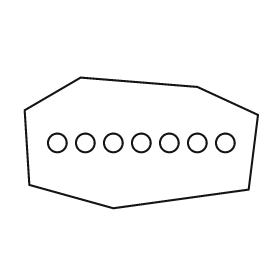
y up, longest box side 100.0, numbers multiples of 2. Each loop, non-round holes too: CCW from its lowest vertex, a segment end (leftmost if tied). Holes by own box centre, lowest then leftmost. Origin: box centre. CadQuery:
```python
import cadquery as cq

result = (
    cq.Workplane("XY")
    .moveTo(-12.0, -28.0)
    .lineTo(46.0, -20.0)
    .lineTo(50.0, 12.0)
    .lineTo(24.0, 24.0)
    .lineTo(-26.0, 28.0)
    .lineTo(-50.0, 14.0)
    .lineTo(-48.0, -18.0)
    .close()
    .moveTo(-36.0, 0.0)
    .circle(4.0)
    .moveTo(-24.0, 0.0)
    .circle(4.0)
    .moveTo(-12.0, 0.0)
    .circle(4.0)
    .moveTo(0.0, 0.0)
    .circle(4.0)
    .moveTo(12.0, 0.0)
    .circle(4.0)
    .moveTo(24.0, 0.0)
    .circle(4.0)
    .moveTo(36.0, 0.0)
    .circle(4.0)
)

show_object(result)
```